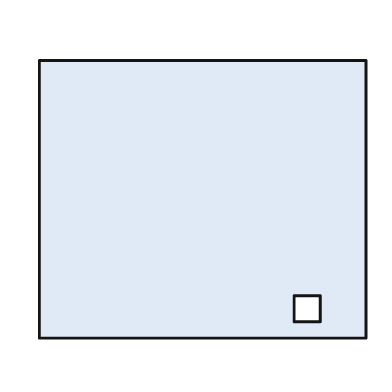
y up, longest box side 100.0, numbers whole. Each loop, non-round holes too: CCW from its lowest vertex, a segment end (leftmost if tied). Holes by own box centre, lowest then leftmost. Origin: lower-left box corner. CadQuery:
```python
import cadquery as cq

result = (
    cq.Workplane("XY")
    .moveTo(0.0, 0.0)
    .lineTo(100.0, 0.0)
    .lineTo(100.0, 85.0)
    .lineTo(0.0, 85.0)
    .close()
    .moveTo(78.0, 5.0)
    .lineTo(86.0, 5.0)
    .lineTo(86.0, 13.0)
    .lineTo(78.0, 13.0)
    .close()
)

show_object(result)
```